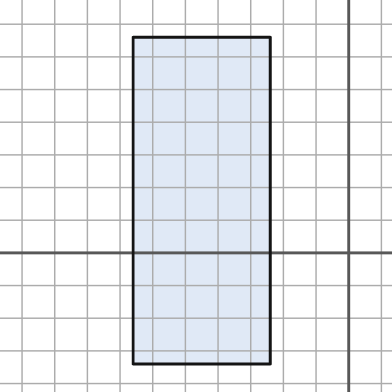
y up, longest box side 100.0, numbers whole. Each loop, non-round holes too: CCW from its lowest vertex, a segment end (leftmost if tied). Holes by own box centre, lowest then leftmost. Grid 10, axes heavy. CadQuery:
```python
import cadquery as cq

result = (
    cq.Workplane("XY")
    .moveTo(-66.0, -34.0)
    .lineTo(-24.0, -34.0)
    .lineTo(-24.0, 66.0)
    .lineTo(-66.0, 66.0)
    .close()
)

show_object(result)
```